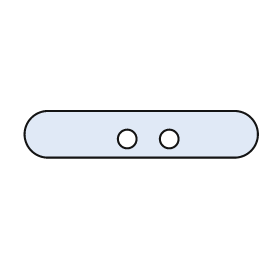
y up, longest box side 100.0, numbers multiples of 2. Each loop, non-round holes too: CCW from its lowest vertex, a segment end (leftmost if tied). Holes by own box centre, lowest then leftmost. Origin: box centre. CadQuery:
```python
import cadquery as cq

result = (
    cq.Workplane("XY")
    .moveTo(-40.0, -10.0)
    .lineTo(40.0, -10.0)
    .threePointArc((50.0, 0.0), (40.0, 10.0))
    .lineTo(-40.0, 10.0)
    .threePointArc((-50.0, 0.0), (-40.0, -10.0))
    .close()
    .moveTo(-6.0, -2.0)
    .circle(4.0)
    .moveTo(12.0, -2.0)
    .circle(4.0)
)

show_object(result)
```